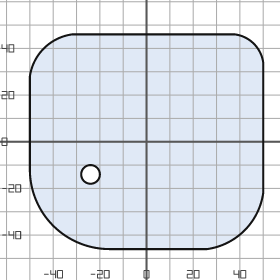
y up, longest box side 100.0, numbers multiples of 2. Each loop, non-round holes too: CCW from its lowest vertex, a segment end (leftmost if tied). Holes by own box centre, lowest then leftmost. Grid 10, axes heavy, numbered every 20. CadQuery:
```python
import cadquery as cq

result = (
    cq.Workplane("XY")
    .moveTo(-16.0, -46.0)
    .lineTo(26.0, -46.0)
    .threePointArc((42.0, -38.0), (50.0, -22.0))
    .lineTo(50.0, 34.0)
    .threePointArc((46.0, 42.0), (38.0, 46.0))
    .lineTo(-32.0, 46.0)
    .threePointArc((-44.0, 40.0), (-50.0, 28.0))
    .lineTo(-50.0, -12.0)
    .threePointArc((-40.0, -36.0), (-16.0, -46.0))
    .close()
    .moveTo(-24.0, -14.0)
    .circle(4.0)
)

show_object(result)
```